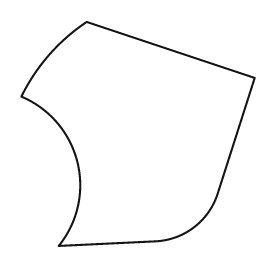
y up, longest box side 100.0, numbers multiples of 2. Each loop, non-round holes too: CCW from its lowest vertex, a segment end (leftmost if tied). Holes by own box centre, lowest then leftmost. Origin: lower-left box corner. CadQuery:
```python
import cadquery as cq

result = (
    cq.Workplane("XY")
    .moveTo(16.0, 0.0)
    .lineTo(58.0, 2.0)
    .threePointArc((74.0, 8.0), (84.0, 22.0))
    .lineTo(100.0, 72.0)
    .lineTo(28.0, 96.0)
    .threePointArc((12.0, 82.0), (0.0, 64.0))
    .threePointArc((24.0, 36.0), (16.0, 0.0))
    .close()
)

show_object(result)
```